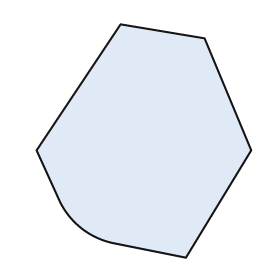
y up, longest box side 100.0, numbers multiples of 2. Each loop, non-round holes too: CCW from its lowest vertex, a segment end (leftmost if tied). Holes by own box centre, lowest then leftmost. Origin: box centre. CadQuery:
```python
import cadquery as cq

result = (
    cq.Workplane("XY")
    .moveTo(18.0, -50.0)
    .lineTo(46.0, -4.0)
    .lineTo(26.0, 44.0)
    .lineTo(-10.0, 50.0)
    .lineTo(-46.0, -4.0)
    .lineTo(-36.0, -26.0)
    .threePointArc((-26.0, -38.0), (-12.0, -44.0))
    .close()
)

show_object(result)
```